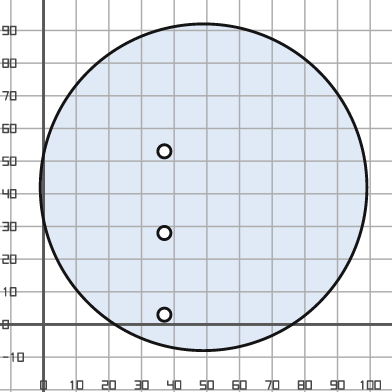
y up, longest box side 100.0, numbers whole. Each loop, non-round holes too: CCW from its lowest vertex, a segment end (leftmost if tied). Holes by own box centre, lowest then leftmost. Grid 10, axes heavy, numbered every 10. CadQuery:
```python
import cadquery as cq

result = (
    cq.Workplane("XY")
    .moveTo(49.0, 42.0)
    .circle(50.0)
    .moveTo(37.0, 3.0)
    .circle(2.0)
    .moveTo(37.0, 28.0)
    .circle(2.0)
    .moveTo(37.0, 53.0)
    .circle(2.0)
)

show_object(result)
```